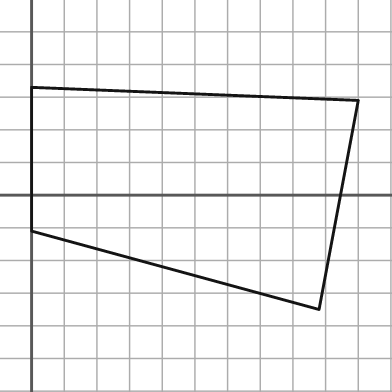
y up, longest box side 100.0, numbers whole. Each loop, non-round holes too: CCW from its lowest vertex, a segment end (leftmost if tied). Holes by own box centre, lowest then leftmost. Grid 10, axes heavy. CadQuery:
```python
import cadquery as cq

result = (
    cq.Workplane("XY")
    .moveTo(88.0, -35.0)
    .lineTo(100.0, 29.0)
    .lineTo(0.0, 33.0)
    .lineTo(0.0, -11.0)
    .close()
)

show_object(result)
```